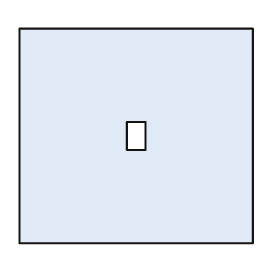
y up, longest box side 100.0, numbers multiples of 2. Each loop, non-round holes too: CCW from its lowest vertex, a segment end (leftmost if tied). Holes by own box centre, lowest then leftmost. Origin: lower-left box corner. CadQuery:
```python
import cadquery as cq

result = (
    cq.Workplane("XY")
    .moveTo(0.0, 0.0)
    .lineTo(100.0, 0.0)
    .lineTo(100.0, 92.0)
    .lineTo(0.0, 92.0)
    .close()
    .moveTo(46.0, 40.0)
    .lineTo(54.0, 40.0)
    .lineTo(54.0, 52.0)
    .lineTo(46.0, 52.0)
    .close()
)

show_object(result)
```